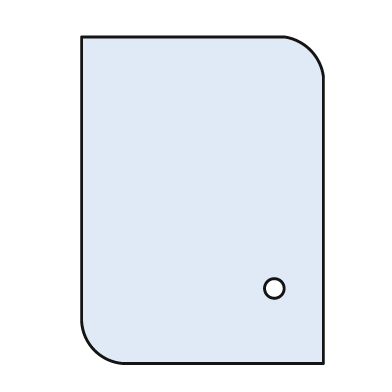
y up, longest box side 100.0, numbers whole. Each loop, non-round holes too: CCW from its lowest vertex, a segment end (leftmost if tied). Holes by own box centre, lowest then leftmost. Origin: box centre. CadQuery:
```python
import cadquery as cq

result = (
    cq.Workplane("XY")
    .moveTo(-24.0, -50.0)
    .lineTo(37.0, -50.0)
    .lineTo(37.0, 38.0)
    .threePointArc((33.0, 46.0), (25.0, 50.0))
    .lineTo(-37.0, 50.0)
    .lineTo(-37.0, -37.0)
    .threePointArc((-33.0, -46.0), (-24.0, -50.0))
    .close()
    .moveTo(22.0, -27.0)
    .circle(3.0)
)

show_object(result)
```